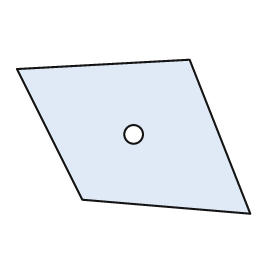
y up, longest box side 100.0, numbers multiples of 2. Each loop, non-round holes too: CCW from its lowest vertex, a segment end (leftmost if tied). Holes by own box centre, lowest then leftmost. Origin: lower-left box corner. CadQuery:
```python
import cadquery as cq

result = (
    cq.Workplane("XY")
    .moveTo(100.0, 0.0)
    .lineTo(74.0, 66.0)
    .lineTo(0.0, 62.0)
    .lineTo(28.0, 6.0)
    .close()
    .moveTo(50.0, 34.0)
    .circle(4.0)
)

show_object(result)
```